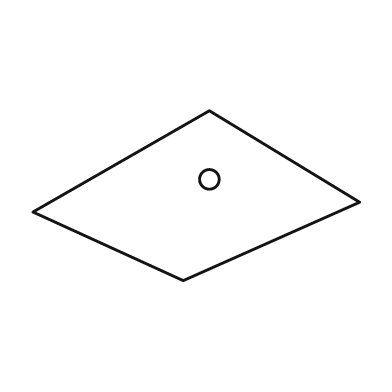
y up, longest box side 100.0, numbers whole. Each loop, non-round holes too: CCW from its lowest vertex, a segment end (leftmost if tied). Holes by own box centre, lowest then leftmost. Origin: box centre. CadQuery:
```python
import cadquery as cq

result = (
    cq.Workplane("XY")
    .moveTo(-4.0, -26.0)
    .lineTo(50.0, -2.0)
    .lineTo(4.0, 26.0)
    .lineTo(-50.0, -5.0)
    .close()
    .moveTo(4.0, 5.0)
    .circle(3.0)
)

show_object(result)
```